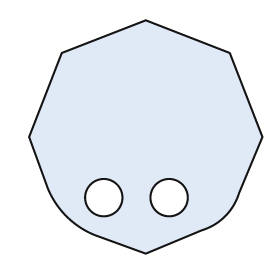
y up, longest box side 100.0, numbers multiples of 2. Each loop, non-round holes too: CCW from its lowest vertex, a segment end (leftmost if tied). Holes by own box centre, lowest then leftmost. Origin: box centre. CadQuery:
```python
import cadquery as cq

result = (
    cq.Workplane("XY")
    .moveTo(0.0, -50.0)
    .lineTo(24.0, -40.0)
    .threePointArc((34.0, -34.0), (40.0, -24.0))
    .lineTo(50.0, 0.0)
    .lineTo(36.0, 36.0)
    .lineTo(0.0, 50.0)
    .lineTo(-36.0, 36.0)
    .lineTo(-50.0, 0.0)
    .lineTo(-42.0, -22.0)
    .threePointArc((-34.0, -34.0), (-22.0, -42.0))
    .close()
    .moveTo(-18.0, -26.0)
    .circle(8.0)
    .moveTo(10.0, -26.0)
    .circle(8.0)
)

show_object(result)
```